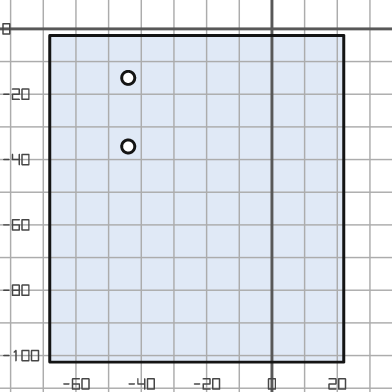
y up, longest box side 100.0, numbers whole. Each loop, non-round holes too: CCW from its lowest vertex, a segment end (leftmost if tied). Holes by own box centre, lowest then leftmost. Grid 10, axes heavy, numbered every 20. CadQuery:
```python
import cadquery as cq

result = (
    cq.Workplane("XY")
    .moveTo(-68.0, -102.0)
    .lineTo(22.0, -102.0)
    .lineTo(22.0, -2.0)
    .lineTo(-68.0, -2.0)
    .close()
    .moveTo(-44.0, -36.0)
    .circle(2.0)
    .moveTo(-44.0, -15.0)
    .circle(2.0)
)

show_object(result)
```